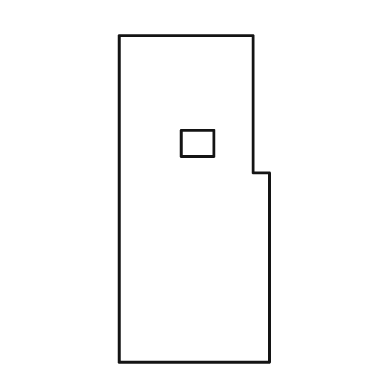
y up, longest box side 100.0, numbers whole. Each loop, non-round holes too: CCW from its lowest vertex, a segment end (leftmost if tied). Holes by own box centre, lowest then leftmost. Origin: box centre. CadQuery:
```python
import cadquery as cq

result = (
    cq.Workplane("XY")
    .moveTo(-23.0, -50.0)
    .lineTo(23.0, -50.0)
    .lineTo(23.0, 8.0)
    .lineTo(18.0, 8.0)
    .lineTo(18.0, 50.0)
    .lineTo(-23.0, 50.0)
    .close()
    .moveTo(-4.0, 13.0)
    .lineTo(6.0, 13.0)
    .lineTo(6.0, 21.0)
    .lineTo(-4.0, 21.0)
    .close()
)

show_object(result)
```